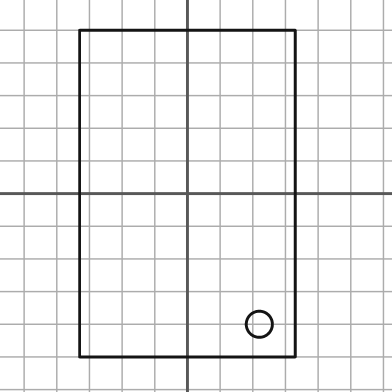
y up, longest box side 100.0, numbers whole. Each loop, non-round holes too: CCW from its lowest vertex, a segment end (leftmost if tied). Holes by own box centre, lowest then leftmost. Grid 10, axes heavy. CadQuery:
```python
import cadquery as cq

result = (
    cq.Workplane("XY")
    .moveTo(-33.0, -50.0)
    .lineTo(33.0, -50.0)
    .lineTo(33.0, 50.0)
    .lineTo(-33.0, 50.0)
    .close()
    .moveTo(22.0, -40.0)
    .circle(4.0)
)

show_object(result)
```